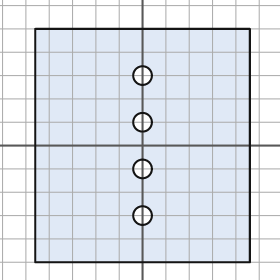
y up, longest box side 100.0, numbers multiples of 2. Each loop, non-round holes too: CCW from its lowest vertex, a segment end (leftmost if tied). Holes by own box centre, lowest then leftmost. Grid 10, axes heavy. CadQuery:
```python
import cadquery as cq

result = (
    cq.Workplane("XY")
    .moveTo(-46.0, -50.0)
    .lineTo(46.0, -50.0)
    .lineTo(46.0, 50.0)
    .lineTo(-46.0, 50.0)
    .close()
    .moveTo(0.0, -30.0)
    .circle(4.0)
    .moveTo(0.0, -10.0)
    .circle(4.0)
    .moveTo(0.0, 10.0)
    .circle(4.0)
    .moveTo(0.0, 30.0)
    .circle(4.0)
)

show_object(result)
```